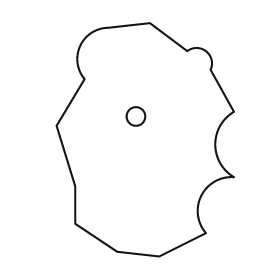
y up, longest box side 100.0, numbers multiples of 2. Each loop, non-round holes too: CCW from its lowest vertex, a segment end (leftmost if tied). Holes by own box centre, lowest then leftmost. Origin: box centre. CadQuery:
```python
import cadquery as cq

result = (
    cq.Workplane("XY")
    .moveTo(6.0, -50.0)
    .lineTo(26.0, -40.0)
    .threePointArc((24.0, -24.0), (38.0, -16.0))
    .threePointArc((30.0, -2.0), (38.0, 12.0))
    .lineTo(28.0, 30.0)
    .threePointArc((26.0, 38.0), (18.0, 38.0))
    .lineTo(2.0, 50.0)
    .lineTo(-16.0, 48.0)
    .threePointArc((-28.0, 40.0), (-26.0, 26.0))
    .lineTo(-38.0, 6.0)
    .lineTo(-30.0, -20.0)
    .lineTo(-30.0, -36.0)
    .lineTo(-12.0, -48.0)
    .close()
    .moveTo(-4.0, 10.0)
    .circle(4.0)
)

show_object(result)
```